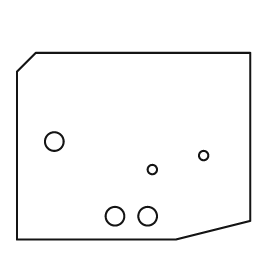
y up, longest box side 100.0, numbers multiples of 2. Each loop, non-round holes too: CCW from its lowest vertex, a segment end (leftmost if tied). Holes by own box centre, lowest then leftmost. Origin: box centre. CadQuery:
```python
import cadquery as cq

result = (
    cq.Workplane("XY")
    .moveTo(-50.0, -40.0)
    .lineTo(18.0, -40.0)
    .lineTo(50.0, -32.0)
    .lineTo(50.0, 40.0)
    .lineTo(-42.0, 40.0)
    .lineTo(-50.0, 32.0)
    .close()
    .moveTo(-8.0, -30.0)
    .circle(4.0)
    .moveTo(6.0, -30.0)
    .circle(4.0)
    .moveTo(8.0, -10.0)
    .circle(2.0)
    .moveTo(30.0, -4.0)
    .circle(2.0)
    .moveTo(-34.0, 2.0)
    .circle(4.0)
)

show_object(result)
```